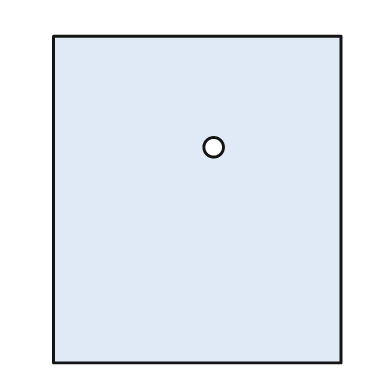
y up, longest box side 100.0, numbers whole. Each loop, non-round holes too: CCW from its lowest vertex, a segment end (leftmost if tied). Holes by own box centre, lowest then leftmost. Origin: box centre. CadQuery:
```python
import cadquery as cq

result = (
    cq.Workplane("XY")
    .moveTo(-44.0, -50.0)
    .lineTo(44.0, -50.0)
    .lineTo(44.0, 50.0)
    .lineTo(-44.0, 50.0)
    .close()
    .moveTo(5.0, 16.0)
    .circle(3.0)
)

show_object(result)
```